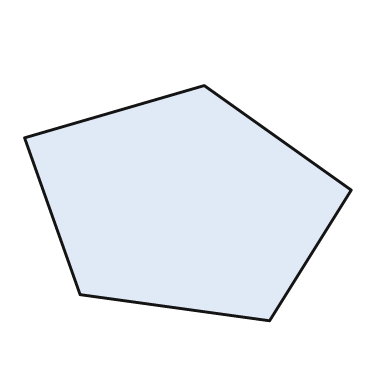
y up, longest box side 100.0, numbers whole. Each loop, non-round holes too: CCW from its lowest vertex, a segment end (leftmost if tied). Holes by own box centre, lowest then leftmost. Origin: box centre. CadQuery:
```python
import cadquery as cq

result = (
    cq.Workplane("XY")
    .moveTo(25.0, -36.0)
    .lineTo(50.0, 4.0)
    .lineTo(5.0, 36.0)
    .lineTo(-50.0, 20.0)
    .lineTo(-33.0, -28.0)
    .close()
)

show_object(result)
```